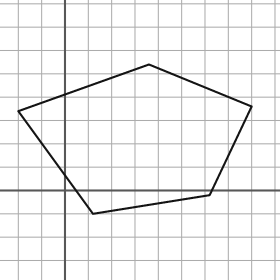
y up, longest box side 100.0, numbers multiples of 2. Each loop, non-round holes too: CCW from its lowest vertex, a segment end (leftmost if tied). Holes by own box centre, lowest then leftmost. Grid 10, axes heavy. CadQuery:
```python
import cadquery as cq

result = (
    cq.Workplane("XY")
    .moveTo(12.0, -10.0)
    .lineTo(62.0, -2.0)
    .lineTo(80.0, 36.0)
    .lineTo(36.0, 54.0)
    .lineTo(-20.0, 34.0)
    .close()
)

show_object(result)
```